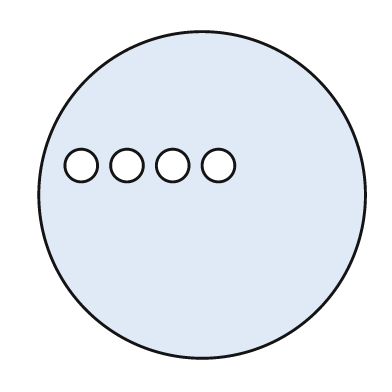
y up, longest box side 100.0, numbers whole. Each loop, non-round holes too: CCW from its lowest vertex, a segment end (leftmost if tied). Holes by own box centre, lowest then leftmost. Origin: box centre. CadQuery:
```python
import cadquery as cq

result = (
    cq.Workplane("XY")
    .moveTo(0.0, 0.0)
    .circle(50.0)
    .moveTo(-37.0, 9.0)
    .circle(5.0)
    .moveTo(-23.0, 9.0)
    .circle(5.0)
    .moveTo(-9.0, 9.0)
    .circle(5.0)
    .moveTo(5.0, 9.0)
    .circle(5.0)
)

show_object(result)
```